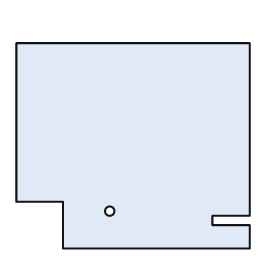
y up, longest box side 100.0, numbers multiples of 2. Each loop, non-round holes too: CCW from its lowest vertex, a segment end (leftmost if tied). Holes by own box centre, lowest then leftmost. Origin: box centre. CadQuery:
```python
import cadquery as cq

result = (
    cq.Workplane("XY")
    .moveTo(-30.0, -44.0)
    .lineTo(50.0, -44.0)
    .lineTo(50.0, -34.0)
    .lineTo(34.0, -34.0)
    .lineTo(34.0, -30.0)
    .lineTo(50.0, -30.0)
    .lineTo(50.0, 44.0)
    .lineTo(-50.0, 44.0)
    .lineTo(-50.0, -24.0)
    .lineTo(-30.0, -24.0)
    .close()
    .moveTo(-10.0, -28.0)
    .circle(2.0)
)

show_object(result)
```